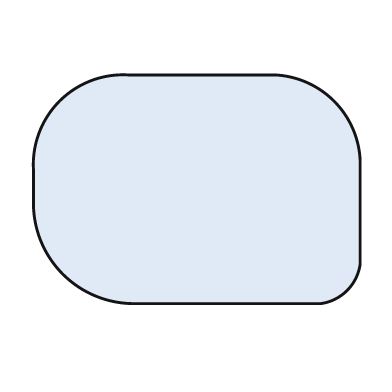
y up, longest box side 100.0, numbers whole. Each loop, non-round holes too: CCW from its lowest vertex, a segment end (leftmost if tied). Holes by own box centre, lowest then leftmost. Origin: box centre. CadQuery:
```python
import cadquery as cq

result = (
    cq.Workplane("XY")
    .moveTo(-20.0, -35.0)
    .lineTo(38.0, -35.0)
    .threePointArc((46.0, -31.0), (50.0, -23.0))
    .lineTo(50.0, 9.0)
    .threePointArc((42.0, 27.0), (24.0, 35.0))
    .lineTo(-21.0, 35.0)
    .threePointArc((-42.0, 27.0), (-50.0, 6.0))
    .lineTo(-50.0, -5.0)
    .threePointArc((-41.0, -26.0), (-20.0, -35.0))
    .close()
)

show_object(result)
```